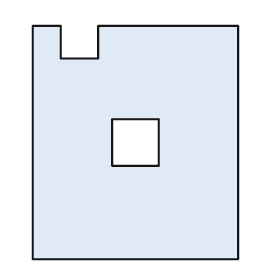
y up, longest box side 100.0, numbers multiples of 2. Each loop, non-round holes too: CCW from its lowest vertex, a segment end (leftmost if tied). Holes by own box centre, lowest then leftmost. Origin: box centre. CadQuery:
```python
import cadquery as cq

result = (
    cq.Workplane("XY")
    .moveTo(-44.0, -50.0)
    .lineTo(44.0, -50.0)
    .lineTo(44.0, 50.0)
    .lineTo(-16.0, 50.0)
    .lineTo(-16.0, 36.0)
    .lineTo(-32.0, 36.0)
    .lineTo(-32.0, 50.0)
    .lineTo(-44.0, 50.0)
    .close()
    .moveTo(-10.0, -10.0)
    .lineTo(10.0, -10.0)
    .lineTo(10.0, 10.0)
    .lineTo(-10.0, 10.0)
    .close()
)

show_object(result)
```